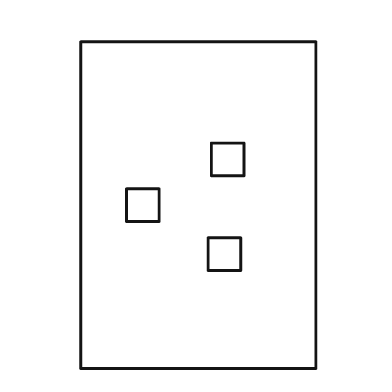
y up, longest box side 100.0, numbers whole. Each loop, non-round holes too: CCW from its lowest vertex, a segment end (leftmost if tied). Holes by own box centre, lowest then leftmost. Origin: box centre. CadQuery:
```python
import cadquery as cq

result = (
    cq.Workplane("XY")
    .moveTo(-36.0, -50.0)
    .lineTo(36.0, -50.0)
    .lineTo(36.0, 50.0)
    .lineTo(-36.0, 50.0)
    .close()
    .moveTo(3.0, -20.0)
    .lineTo(13.0, -20.0)
    .lineTo(13.0, -10.0)
    .lineTo(3.0, -10.0)
    .close()
    .moveTo(-22.0, -5.0)
    .lineTo(-12.0, -5.0)
    .lineTo(-12.0, 5.0)
    .lineTo(-22.0, 5.0)
    .close()
    .moveTo(4.0, 9.0)
    .lineTo(14.0, 9.0)
    .lineTo(14.0, 19.0)
    .lineTo(4.0, 19.0)
    .close()
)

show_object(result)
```